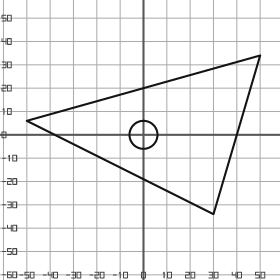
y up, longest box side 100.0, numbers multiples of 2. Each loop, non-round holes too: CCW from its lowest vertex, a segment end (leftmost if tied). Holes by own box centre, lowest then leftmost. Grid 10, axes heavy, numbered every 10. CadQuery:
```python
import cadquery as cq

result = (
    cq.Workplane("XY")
    .moveTo(30.0, -34.0)
    .lineTo(50.0, 34.0)
    .lineTo(-50.0, 6.0)
    .close()
    .moveTo(0.0, 0.0)
    .circle(6.0)
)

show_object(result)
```